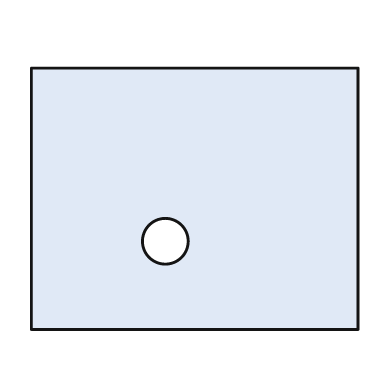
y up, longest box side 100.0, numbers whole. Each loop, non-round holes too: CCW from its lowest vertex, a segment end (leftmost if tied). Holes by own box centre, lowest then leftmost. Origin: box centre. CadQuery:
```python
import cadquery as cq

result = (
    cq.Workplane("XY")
    .moveTo(-50.0, -40.0)
    .lineTo(50.0, -40.0)
    .lineTo(50.0, 40.0)
    .lineTo(-50.0, 40.0)
    .close()
    .moveTo(-9.0, -13.0)
    .circle(7.0)
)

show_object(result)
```